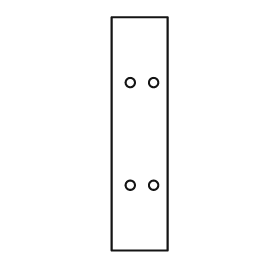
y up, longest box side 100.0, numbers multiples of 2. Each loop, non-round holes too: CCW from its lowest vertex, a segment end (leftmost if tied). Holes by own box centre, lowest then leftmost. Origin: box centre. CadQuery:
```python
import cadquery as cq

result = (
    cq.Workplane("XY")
    .moveTo(-12.0, -50.0)
    .lineTo(12.0, -50.0)
    .lineTo(12.0, 50.0)
    .lineTo(-12.0, 50.0)
    .close()
    .moveTo(-4.0, -22.0)
    .circle(2.0)
    .moveTo(6.0, -22.0)
    .circle(2.0)
    .moveTo(-4.0, 22.0)
    .circle(2.0)
    .moveTo(6.0, 22.0)
    .circle(2.0)
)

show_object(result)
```